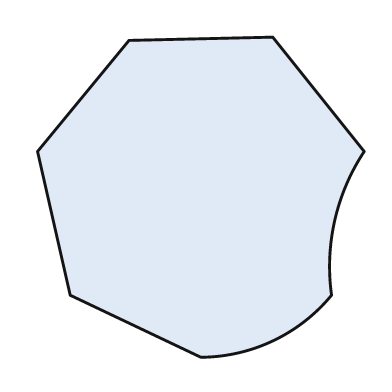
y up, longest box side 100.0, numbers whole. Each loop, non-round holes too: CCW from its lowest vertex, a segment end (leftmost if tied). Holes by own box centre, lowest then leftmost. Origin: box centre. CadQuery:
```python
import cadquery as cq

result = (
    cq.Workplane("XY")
    .moveTo(0.0, -49.0)
    .threePointArc((22.0, -44.0), (40.0, -30.0))
    .threePointArc((41.0, -7.0), (50.0, 14.0))
    .lineTo(22.0, 49.0)
    .lineTo(-22.0, 48.0)
    .lineTo(-50.0, 14.0)
    .lineTo(-40.0, -30.0)
    .close()
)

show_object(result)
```